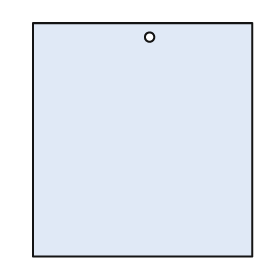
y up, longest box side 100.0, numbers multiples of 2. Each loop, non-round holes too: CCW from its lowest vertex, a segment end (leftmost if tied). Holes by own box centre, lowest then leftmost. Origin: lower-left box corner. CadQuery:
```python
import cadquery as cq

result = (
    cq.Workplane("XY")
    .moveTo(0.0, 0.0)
    .lineTo(94.0, 0.0)
    .lineTo(94.0, 100.0)
    .lineTo(0.0, 100.0)
    .close()
    .moveTo(50.0, 94.0)
    .circle(2.0)
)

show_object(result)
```